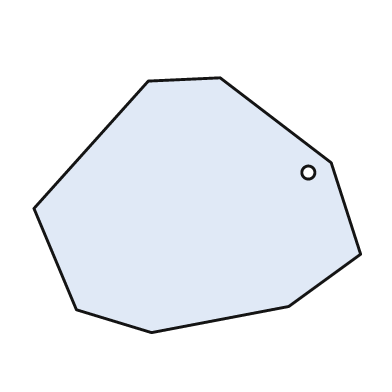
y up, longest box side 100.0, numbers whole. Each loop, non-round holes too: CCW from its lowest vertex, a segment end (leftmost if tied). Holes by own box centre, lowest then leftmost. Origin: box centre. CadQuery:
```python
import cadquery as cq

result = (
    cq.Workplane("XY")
    .moveTo(-14.0, -39.0)
    .lineTo(28.0, -31.0)
    .lineTo(50.0, -15.0)
    .lineTo(41.0, 13.0)
    .lineTo(7.0, 39.0)
    .lineTo(-15.0, 38.0)
    .lineTo(-50.0, -1.0)
    .lineTo(-37.0, -32.0)
    .close()
    .moveTo(34.0, 10.0)
    .circle(2.0)
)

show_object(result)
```